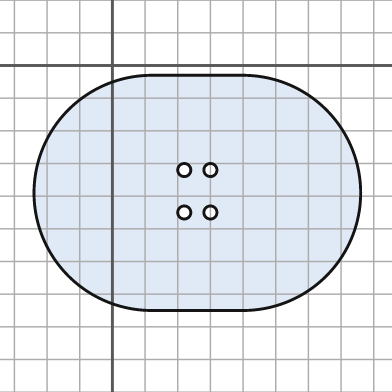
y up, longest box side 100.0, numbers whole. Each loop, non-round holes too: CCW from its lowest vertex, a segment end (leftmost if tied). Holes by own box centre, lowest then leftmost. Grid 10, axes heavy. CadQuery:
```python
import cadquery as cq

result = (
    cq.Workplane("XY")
    .moveTo(12.0, -75.0)
    .lineTo(40.0, -75.0)
    .threePointArc((76.0, -39.0), (40.0, -3.0))
    .lineTo(12.0, -3.0)
    .threePointArc((-24.0, -39.0), (12.0, -75.0))
    .close()
    .moveTo(22.0, -45.0)
    .circle(2.0)
    .moveTo(30.0, -45.0)
    .circle(2.0)
    .moveTo(22.0, -32.0)
    .circle(2.0)
    .moveTo(30.0, -32.0)
    .circle(2.0)
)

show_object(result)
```